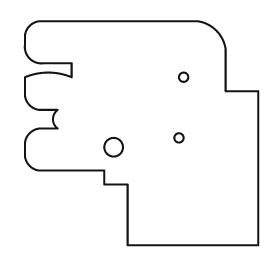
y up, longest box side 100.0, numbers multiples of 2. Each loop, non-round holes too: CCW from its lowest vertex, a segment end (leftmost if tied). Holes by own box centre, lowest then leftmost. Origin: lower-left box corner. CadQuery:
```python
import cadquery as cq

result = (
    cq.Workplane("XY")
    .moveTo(44.0, 0.0)
    .lineTo(100.0, 0.0)
    .lineTo(100.0, 66.0)
    .lineTo(86.0, 66.0)
    .lineTo(86.0, 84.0)
    .threePointArc((82.0, 92.0), (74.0, 96.0))
    .lineTo(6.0, 96.0)
    .threePointArc((2.0, 94.0), (0.0, 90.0))
    .lineTo(0.0, 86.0)
    .threePointArc((2.0, 80.0), (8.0, 78.0))
    .lineTo(20.0, 78.0)
    .lineTo(20.0, 72.0)
    .threePointArc((10.0, 74.0), (0.0, 72.0))
    .lineTo(0.0, 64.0)
    .threePointArc((2.0, 60.0), (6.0, 58.0))
    .lineTo(14.0, 58.0)
    .threePointArc((12.0, 54.0), (14.0, 50.0))
    .lineTo(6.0, 50.0)
    .threePointArc((2.0, 48.0), (0.0, 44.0))
    .lineTo(0.0, 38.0)
    .threePointArc((2.0, 34.0), (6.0, 32.0))
    .lineTo(34.0, 32.0)
    .lineTo(34.0, 26.0)
    .lineTo(44.0, 26.0)
    .close()
    .moveTo(38.0, 42.0)
    .circle(4.0)
    .moveTo(66.0, 46.0)
    .circle(2.0)
    .moveTo(68.0, 72.0)
    .circle(2.0)
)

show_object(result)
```